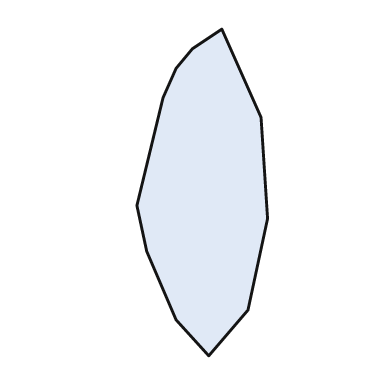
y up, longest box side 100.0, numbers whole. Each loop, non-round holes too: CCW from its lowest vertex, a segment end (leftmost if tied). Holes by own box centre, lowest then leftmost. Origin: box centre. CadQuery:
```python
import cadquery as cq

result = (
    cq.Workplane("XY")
    .moveTo(2.0, -50.0)
    .lineTo(14.0, -36.0)
    .lineTo(20.0, -8.0)
    .lineTo(18.0, 23.0)
    .lineTo(6.0, 50.0)
    .lineTo(-3.0, 44.0)
    .lineTo(-8.0, 38.0)
    .lineTo(-12.0, 29.0)
    .lineTo(-20.0, -4.0)
    .lineTo(-17.0, -18.0)
    .lineTo(-8.0, -39.0)
    .close()
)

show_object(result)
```